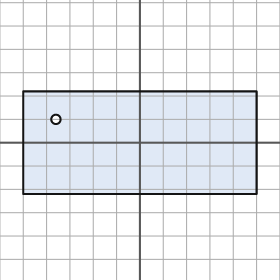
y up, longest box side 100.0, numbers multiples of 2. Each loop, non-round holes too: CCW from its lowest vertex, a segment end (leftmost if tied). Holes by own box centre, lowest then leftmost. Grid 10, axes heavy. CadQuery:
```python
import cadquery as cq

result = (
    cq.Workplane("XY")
    .moveTo(-50.0, -22.0)
    .lineTo(50.0, -22.0)
    .lineTo(50.0, 22.0)
    .lineTo(-50.0, 22.0)
    .close()
    .moveTo(-36.0, 10.0)
    .circle(2.0)
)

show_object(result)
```